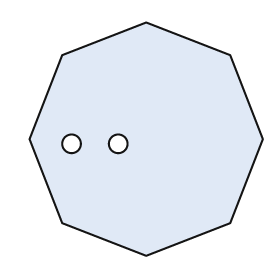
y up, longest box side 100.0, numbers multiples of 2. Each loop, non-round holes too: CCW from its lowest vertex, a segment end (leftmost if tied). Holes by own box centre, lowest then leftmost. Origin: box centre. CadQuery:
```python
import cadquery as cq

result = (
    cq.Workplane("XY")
    .moveTo(0.0, -50.0)
    .lineTo(36.0, -36.0)
    .lineTo(50.0, 0.0)
    .lineTo(36.0, 36.0)
    .lineTo(0.0, 50.0)
    .lineTo(-36.0, 36.0)
    .lineTo(-50.0, 0.0)
    .lineTo(-36.0, -36.0)
    .close()
    .moveTo(-32.0, -2.0)
    .circle(4.0)
    .moveTo(-12.0, -2.0)
    .circle(4.0)
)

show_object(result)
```